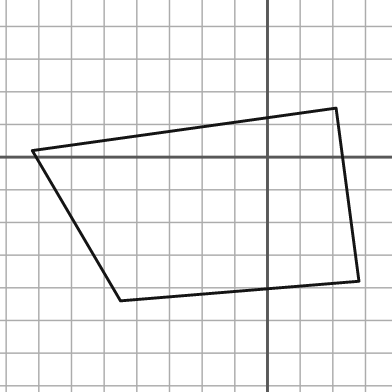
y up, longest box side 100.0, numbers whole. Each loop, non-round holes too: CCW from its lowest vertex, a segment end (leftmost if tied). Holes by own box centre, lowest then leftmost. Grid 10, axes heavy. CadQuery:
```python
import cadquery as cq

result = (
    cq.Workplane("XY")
    .moveTo(-45.0, -44.0)
    .lineTo(28.0, -38.0)
    .lineTo(21.0, 15.0)
    .lineTo(-72.0, 2.0)
    .close()
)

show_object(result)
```